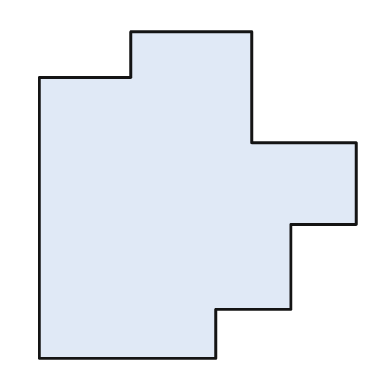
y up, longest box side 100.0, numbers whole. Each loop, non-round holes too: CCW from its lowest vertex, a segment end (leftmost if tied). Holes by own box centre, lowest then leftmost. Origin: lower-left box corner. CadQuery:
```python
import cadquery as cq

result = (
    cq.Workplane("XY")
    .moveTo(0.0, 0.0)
    .lineTo(54.0, 0.0)
    .lineTo(54.0, 15.0)
    .lineTo(77.0, 15.0)
    .lineTo(77.0, 41.0)
    .lineTo(97.0, 41.0)
    .lineTo(97.0, 66.0)
    .lineTo(65.0, 66.0)
    .lineTo(65.0, 100.0)
    .lineTo(28.0, 100.0)
    .lineTo(28.0, 86.0)
    .lineTo(0.0, 86.0)
    .close()
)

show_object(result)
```